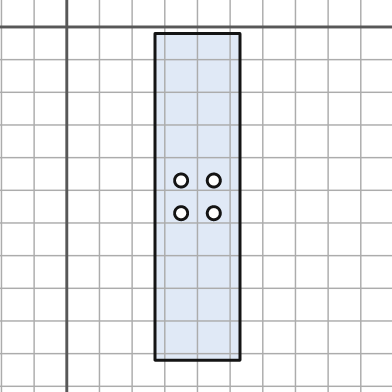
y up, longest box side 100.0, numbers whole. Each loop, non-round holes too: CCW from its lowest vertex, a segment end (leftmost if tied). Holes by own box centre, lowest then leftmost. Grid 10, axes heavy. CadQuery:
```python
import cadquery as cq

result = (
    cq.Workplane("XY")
    .moveTo(27.0, -102.0)
    .lineTo(53.0, -102.0)
    .lineTo(53.0, -2.0)
    .lineTo(27.0, -2.0)
    .close()
    .moveTo(35.0, -57.0)
    .circle(2.0)
    .moveTo(45.0, -57.0)
    .circle(2.0)
    .moveTo(35.0, -47.0)
    .circle(2.0)
    .moveTo(45.0, -47.0)
    .circle(2.0)
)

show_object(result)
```